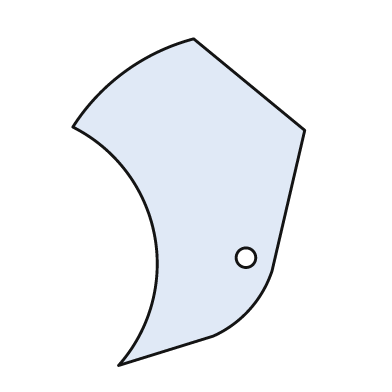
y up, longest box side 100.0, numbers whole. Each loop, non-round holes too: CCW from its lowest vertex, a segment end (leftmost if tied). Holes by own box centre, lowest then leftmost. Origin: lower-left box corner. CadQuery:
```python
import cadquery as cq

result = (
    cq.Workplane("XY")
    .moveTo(14.0, 0.0)
    .lineTo(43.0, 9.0)
    .threePointArc((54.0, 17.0), (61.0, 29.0))
    .lineTo(71.0, 72.0)
    .lineTo(37.0, 100.0)
    .threePointArc((16.0, 90.0), (0.0, 73.0))
    .threePointArc((25.0, 40.0), (14.0, 0.0))
    .close()
    .moveTo(53.0, 33.0)
    .circle(3.0)
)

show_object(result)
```